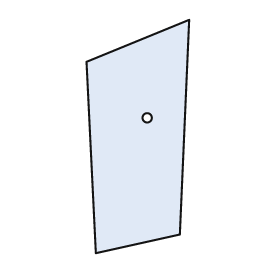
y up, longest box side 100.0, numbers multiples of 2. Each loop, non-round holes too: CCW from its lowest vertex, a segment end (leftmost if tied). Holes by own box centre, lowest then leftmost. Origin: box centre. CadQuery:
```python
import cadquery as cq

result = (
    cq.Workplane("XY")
    .moveTo(-18.0, -50.0)
    .lineTo(18.0, -42.0)
    .lineTo(22.0, 50.0)
    .lineTo(-22.0, 32.0)
    .close()
    .moveTo(4.0, 8.0)
    .circle(2.0)
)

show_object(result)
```